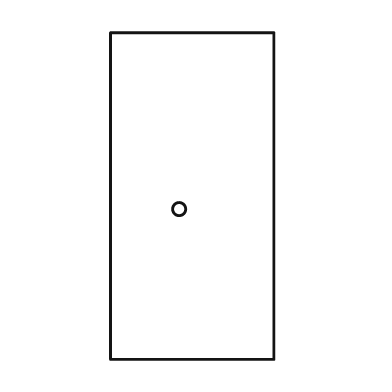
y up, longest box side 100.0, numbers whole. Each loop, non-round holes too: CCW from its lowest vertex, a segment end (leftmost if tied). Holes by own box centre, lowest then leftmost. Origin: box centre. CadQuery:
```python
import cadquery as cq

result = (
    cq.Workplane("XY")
    .moveTo(-25.0, -50.0)
    .lineTo(25.0, -50.0)
    .lineTo(25.0, 50.0)
    .lineTo(-25.0, 50.0)
    .close()
    .moveTo(-4.0, -4.0)
    .circle(2.0)
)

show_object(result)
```